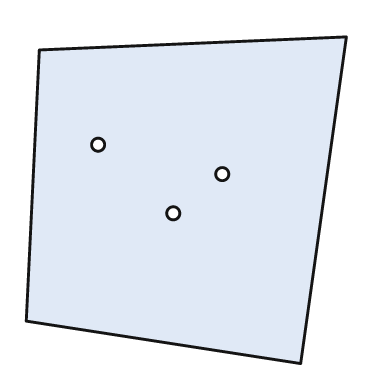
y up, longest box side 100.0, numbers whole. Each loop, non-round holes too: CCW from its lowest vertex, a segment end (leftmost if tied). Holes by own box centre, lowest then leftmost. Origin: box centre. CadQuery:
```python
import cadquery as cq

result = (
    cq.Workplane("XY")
    .moveTo(35.0, -50.0)
    .lineTo(49.0, 50.0)
    .lineTo(-45.0, 46.0)
    .lineTo(-49.0, -37.0)
    .close()
    .moveTo(-4.0, -4.0)
    .circle(2.0)
    .moveTo(11.0, 8.0)
    .circle(2.0)
    .moveTo(-27.0, 17.0)
    .circle(2.0)
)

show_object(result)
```